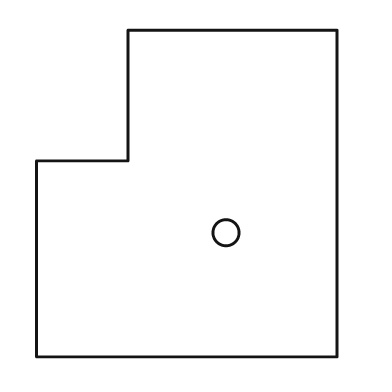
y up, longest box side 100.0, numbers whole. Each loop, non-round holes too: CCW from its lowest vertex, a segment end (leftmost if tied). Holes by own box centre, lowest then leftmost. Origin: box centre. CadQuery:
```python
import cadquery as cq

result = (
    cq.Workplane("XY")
    .moveTo(-46.0, -50.0)
    .lineTo(46.0, -50.0)
    .lineTo(46.0, 50.0)
    .lineTo(-18.0, 50.0)
    .lineTo(-18.0, 10.0)
    .lineTo(-46.0, 10.0)
    .close()
    .moveTo(12.0, -12.0)
    .circle(4.0)
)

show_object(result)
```